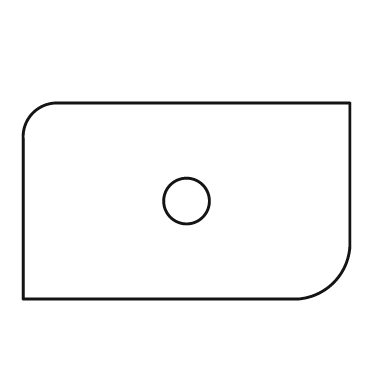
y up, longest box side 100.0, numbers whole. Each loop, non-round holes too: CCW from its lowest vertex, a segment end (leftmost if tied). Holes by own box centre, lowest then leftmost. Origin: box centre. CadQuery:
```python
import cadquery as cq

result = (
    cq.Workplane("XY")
    .moveTo(-50.0, -30.0)
    .lineTo(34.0, -30.0)
    .threePointArc((45.0, -25.0), (50.0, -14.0))
    .lineTo(50.0, 30.0)
    .lineTo(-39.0, 30.0)
    .threePointArc((-47.0, 27.0), (-50.0, 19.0))
    .close()
    .moveTo(0.0, 0.0)
    .circle(7.0)
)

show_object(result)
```